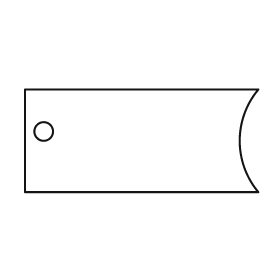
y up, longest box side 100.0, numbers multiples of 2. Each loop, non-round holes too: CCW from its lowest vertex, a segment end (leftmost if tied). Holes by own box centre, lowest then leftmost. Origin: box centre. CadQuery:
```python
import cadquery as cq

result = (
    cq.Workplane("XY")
    .moveTo(-50.0, -22.0)
    .lineTo(50.0, -22.0)
    .threePointArc((42.0, 0.0), (50.0, 22.0))
    .lineTo(-50.0, 22.0)
    .close()
    .moveTo(-42.0, 4.0)
    .circle(4.0)
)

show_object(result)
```